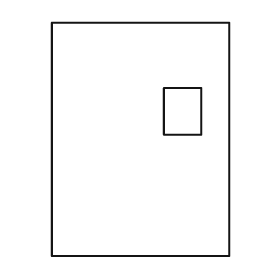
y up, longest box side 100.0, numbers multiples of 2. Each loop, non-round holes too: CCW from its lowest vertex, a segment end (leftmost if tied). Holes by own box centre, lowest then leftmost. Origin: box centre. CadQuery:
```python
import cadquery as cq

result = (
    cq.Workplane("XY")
    .moveTo(-38.0, -50.0)
    .lineTo(38.0, -50.0)
    .lineTo(38.0, 50.0)
    .lineTo(-38.0, 50.0)
    .close()
    .moveTo(10.0, 2.0)
    .lineTo(26.0, 2.0)
    .lineTo(26.0, 22.0)
    .lineTo(10.0, 22.0)
    .close()
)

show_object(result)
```